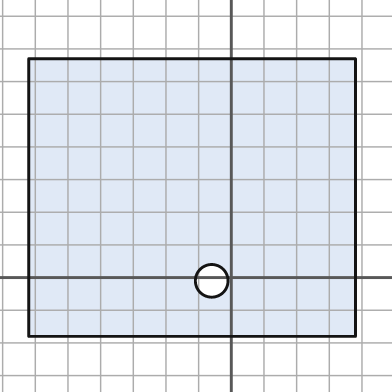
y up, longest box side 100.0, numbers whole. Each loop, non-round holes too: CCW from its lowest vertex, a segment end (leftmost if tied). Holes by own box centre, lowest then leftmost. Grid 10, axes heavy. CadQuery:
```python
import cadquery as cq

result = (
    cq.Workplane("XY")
    .moveTo(-62.0, -18.0)
    .lineTo(38.0, -18.0)
    .lineTo(38.0, 67.0)
    .lineTo(-62.0, 67.0)
    .close()
    .moveTo(-6.0, -1.0)
    .circle(5.0)
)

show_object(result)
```